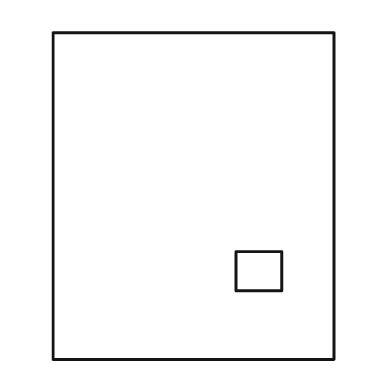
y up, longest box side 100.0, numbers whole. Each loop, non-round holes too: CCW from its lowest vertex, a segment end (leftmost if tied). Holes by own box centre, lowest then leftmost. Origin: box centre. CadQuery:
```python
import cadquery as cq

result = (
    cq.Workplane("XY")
    .moveTo(-43.0, -50.0)
    .lineTo(43.0, -50.0)
    .lineTo(43.0, 50.0)
    .lineTo(-43.0, 50.0)
    .close()
    .moveTo(13.0, -29.0)
    .lineTo(27.0, -29.0)
    .lineTo(27.0, -17.0)
    .lineTo(13.0, -17.0)
    .close()
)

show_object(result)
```